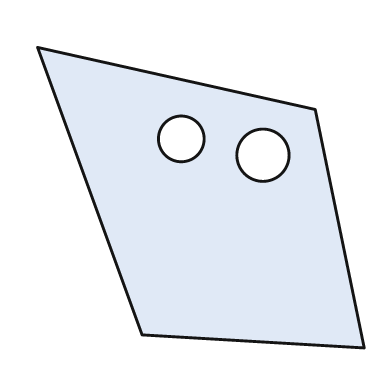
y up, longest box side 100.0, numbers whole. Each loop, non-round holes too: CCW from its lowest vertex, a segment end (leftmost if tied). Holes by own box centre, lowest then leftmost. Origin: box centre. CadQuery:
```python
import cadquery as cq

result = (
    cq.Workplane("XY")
    .moveTo(50.0, -46.0)
    .lineTo(35.0, 27.0)
    .lineTo(-50.0, 46.0)
    .lineTo(-18.0, -42.0)
    .close()
    .moveTo(19.0, 13.0)
    .circle(8.0)
    .moveTo(-6.0, 18.0)
    .circle(7.0)
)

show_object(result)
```